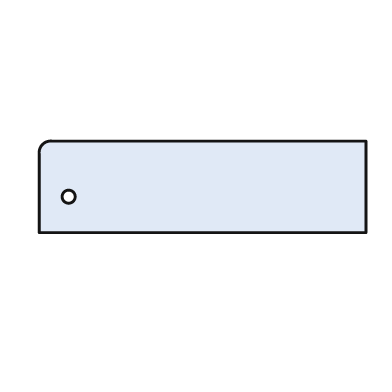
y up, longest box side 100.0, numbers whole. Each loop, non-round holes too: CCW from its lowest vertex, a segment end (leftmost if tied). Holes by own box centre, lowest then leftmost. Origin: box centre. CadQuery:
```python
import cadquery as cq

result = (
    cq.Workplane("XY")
    .moveTo(-50.0, -14.0)
    .lineTo(50.0, -14.0)
    .lineTo(50.0, 14.0)
    .lineTo(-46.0, 14.0)
    .threePointArc((-49.0, 13.0), (-50.0, 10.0))
    .close()
    .moveTo(-41.0, -3.0)
    .circle(2.0)
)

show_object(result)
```